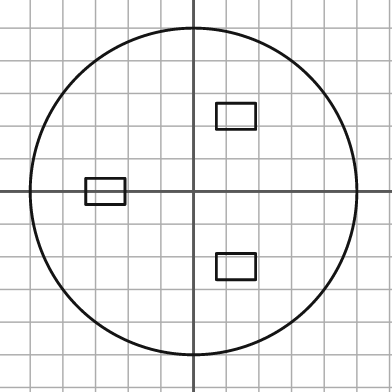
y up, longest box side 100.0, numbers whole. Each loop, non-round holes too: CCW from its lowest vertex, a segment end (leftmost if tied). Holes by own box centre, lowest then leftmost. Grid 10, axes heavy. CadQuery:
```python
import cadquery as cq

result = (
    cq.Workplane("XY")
    .moveTo(0.0, 0.0)
    .circle(50.0)
    .moveTo(7.0, -27.0)
    .lineTo(19.0, -27.0)
    .lineTo(19.0, -19.0)
    .lineTo(7.0, -19.0)
    .close()
    .moveTo(-33.0, -4.0)
    .lineTo(-21.0, -4.0)
    .lineTo(-21.0, 4.0)
    .lineTo(-33.0, 4.0)
    .close()
    .moveTo(7.0, 19.0)
    .lineTo(19.0, 19.0)
    .lineTo(19.0, 27.0)
    .lineTo(7.0, 27.0)
    .close()
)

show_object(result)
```